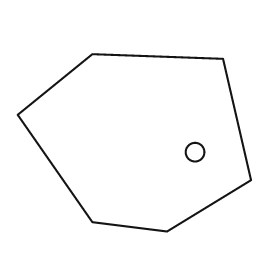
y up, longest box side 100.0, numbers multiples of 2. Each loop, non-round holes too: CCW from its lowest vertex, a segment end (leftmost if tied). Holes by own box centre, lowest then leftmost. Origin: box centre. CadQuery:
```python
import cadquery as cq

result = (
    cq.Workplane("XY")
    .moveTo(14.0, -38.0)
    .lineTo(50.0, -16.0)
    .lineTo(38.0, 36.0)
    .lineTo(-18.0, 38.0)
    .lineTo(-50.0, 12.0)
    .lineTo(-18.0, -34.0)
    .close()
    .moveTo(26.0, -4.0)
    .circle(4.0)
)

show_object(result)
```